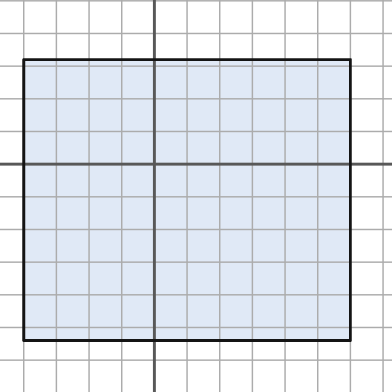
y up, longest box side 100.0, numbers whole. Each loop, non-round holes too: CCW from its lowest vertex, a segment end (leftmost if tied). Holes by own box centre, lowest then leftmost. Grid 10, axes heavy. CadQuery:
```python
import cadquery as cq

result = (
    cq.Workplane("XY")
    .moveTo(-40.0, -54.0)
    .lineTo(60.0, -54.0)
    .lineTo(60.0, 32.0)
    .lineTo(-40.0, 32.0)
    .close()
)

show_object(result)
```